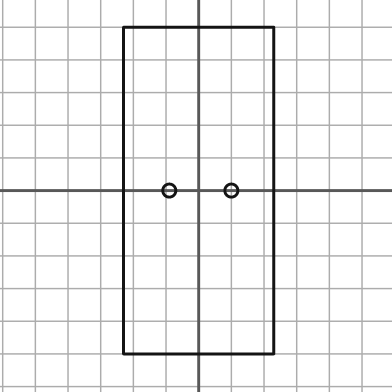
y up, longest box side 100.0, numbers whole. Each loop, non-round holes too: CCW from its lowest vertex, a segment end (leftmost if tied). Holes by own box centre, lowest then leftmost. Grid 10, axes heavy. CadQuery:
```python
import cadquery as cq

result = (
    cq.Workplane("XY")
    .moveTo(-23.0, -50.0)
    .lineTo(23.0, -50.0)
    .lineTo(23.0, 50.0)
    .lineTo(-23.0, 50.0)
    .close()
    .moveTo(-9.0, 0.0)
    .circle(2.0)
    .moveTo(10.0, 0.0)
    .circle(2.0)
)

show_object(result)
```